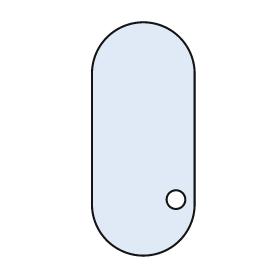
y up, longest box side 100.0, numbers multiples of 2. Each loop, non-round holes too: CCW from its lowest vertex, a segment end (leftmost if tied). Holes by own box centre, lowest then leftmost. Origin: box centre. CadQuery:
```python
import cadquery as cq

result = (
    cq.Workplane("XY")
    .moveTo(-22.0, -28.0)
    .threePointArc((0.0, -50.0), (22.0, -28.0))
    .lineTo(22.0, 28.0)
    .threePointArc((0.0, 50.0), (-22.0, 28.0))
    .close()
    .moveTo(14.0, -26.0)
    .circle(4.0)
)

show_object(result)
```